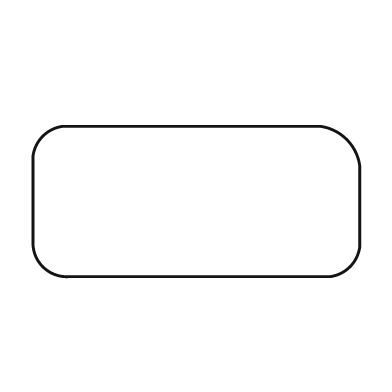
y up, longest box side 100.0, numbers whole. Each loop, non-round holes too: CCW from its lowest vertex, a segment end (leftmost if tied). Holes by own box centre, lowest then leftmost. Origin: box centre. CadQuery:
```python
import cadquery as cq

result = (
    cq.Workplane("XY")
    .moveTo(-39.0, -23.0)
    .lineTo(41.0, -23.0)
    .threePointArc((47.0, -20.0), (50.0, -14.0))
    .lineTo(50.0, 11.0)
    .threePointArc((46.0, 19.0), (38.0, 23.0))
    .lineTo(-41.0, 23.0)
    .threePointArc((-47.0, 20.0), (-50.0, 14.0))
    .lineTo(-50.0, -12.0)
    .threePointArc((-47.0, -20.0), (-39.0, -23.0))
    .close()
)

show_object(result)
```